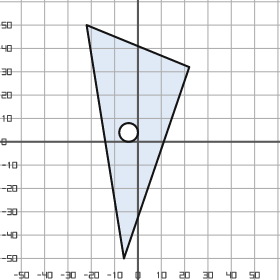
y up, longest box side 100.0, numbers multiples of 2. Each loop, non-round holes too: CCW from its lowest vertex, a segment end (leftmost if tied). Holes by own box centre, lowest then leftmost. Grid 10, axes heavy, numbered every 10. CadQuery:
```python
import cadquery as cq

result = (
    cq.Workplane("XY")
    .moveTo(-6.0, -50.0)
    .lineTo(22.0, 32.0)
    .lineTo(-22.0, 50.0)
    .close()
    .moveTo(-4.0, 4.0)
    .circle(4.0)
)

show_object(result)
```